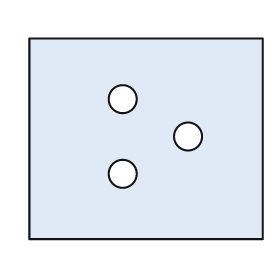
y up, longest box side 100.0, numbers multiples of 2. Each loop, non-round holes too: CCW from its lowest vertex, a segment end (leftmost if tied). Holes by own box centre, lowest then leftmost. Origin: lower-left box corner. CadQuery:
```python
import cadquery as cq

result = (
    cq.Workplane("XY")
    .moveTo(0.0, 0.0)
    .lineTo(100.0, 0.0)
    .lineTo(100.0, 86.0)
    .lineTo(0.0, 86.0)
    .close()
    .moveTo(40.0, 28.0)
    .circle(6.0)
    .moveTo(68.0, 44.0)
    .circle(6.0)
    .moveTo(40.0, 60.0)
    .circle(6.0)
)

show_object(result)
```